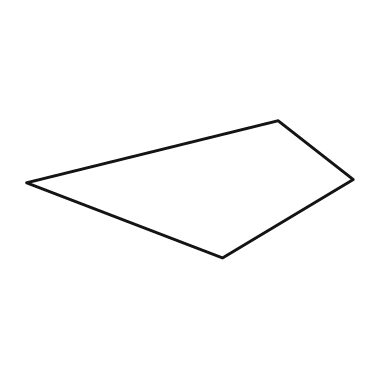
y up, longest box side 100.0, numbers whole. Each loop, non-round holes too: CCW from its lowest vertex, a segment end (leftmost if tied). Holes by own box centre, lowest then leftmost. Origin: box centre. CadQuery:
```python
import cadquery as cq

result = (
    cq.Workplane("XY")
    .moveTo(10.0, -21.0)
    .lineTo(50.0, 3.0)
    .lineTo(27.0, 21.0)
    .lineTo(-50.0, 2.0)
    .close()
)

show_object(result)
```